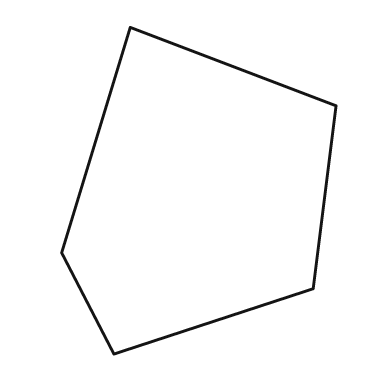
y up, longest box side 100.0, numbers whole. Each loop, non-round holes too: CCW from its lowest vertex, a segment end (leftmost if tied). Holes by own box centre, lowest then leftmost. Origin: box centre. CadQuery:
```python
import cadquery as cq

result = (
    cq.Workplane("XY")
    .moveTo(-26.0, -50.0)
    .lineTo(35.0, -30.0)
    .lineTo(42.0, 26.0)
    .lineTo(-21.0, 50.0)
    .lineTo(-42.0, -19.0)
    .close()
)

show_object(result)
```